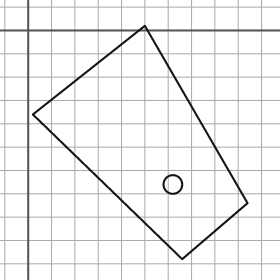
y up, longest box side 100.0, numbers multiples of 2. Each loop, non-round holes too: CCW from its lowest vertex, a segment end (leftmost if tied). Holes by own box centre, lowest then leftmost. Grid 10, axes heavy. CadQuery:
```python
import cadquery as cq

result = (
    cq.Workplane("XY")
    .moveTo(66.0, -98.0)
    .lineTo(94.0, -74.0)
    .lineTo(50.0, 2.0)
    .lineTo(2.0, -36.0)
    .close()
    .moveTo(62.0, -66.0)
    .circle(4.0)
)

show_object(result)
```